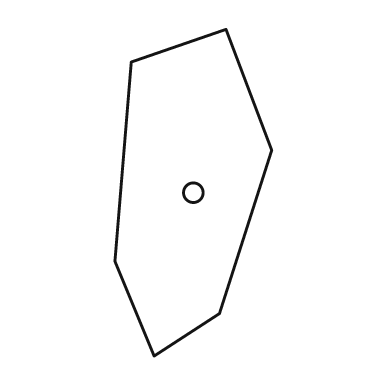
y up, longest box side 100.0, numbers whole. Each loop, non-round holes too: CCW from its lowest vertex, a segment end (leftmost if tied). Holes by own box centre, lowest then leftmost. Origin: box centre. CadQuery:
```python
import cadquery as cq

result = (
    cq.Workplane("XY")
    .moveTo(-12.0, -50.0)
    .lineTo(8.0, -37.0)
    .lineTo(24.0, 13.0)
    .lineTo(10.0, 50.0)
    .lineTo(-19.0, 40.0)
    .lineTo(-24.0, -21.0)
    .close()
    .moveTo(0.0, 0.0)
    .circle(3.0)
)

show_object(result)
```